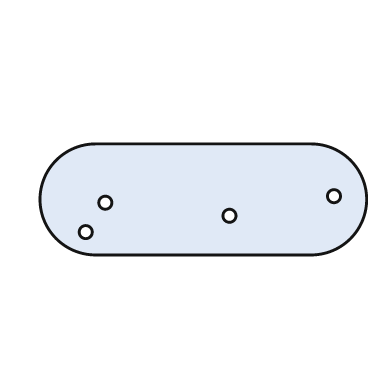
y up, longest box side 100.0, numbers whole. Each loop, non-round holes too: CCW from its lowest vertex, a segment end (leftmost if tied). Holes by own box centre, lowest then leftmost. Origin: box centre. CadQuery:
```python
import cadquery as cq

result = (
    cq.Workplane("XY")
    .moveTo(-33.0, -17.0)
    .lineTo(33.0, -17.0)
    .threePointArc((50.0, 0.0), (33.0, 17.0))
    .lineTo(-33.0, 17.0)
    .threePointArc((-50.0, 0.0), (-33.0, -17.0))
    .close()
    .moveTo(-36.0, -10.0)
    .circle(2.0)
    .moveTo(8.0, -5.0)
    .circle(2.0)
    .moveTo(-30.0, -1.0)
    .circle(2.0)
    .moveTo(40.0, 1.0)
    .circle(2.0)
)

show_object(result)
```